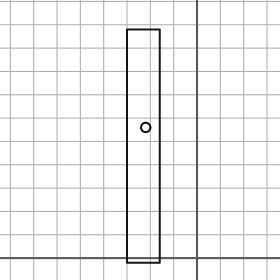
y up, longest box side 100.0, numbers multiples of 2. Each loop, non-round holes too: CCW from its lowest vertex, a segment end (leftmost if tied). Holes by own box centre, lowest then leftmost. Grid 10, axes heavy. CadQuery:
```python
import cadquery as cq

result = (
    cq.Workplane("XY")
    .moveTo(-30.0, -2.0)
    .lineTo(-16.0, -2.0)
    .lineTo(-16.0, 98.0)
    .lineTo(-30.0, 98.0)
    .close()
    .moveTo(-22.0, 56.0)
    .circle(2.0)
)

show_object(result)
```